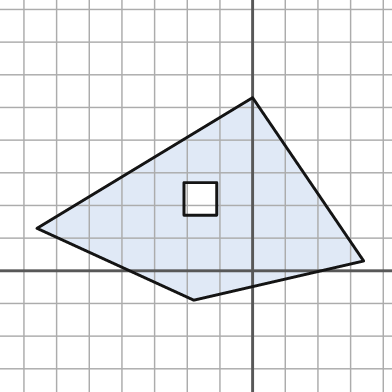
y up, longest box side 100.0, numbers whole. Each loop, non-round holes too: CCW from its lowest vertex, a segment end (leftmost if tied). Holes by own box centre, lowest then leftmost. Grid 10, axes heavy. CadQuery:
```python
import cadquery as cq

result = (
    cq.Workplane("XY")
    .moveTo(-18.0, -9.0)
    .lineTo(34.0, 3.0)
    .lineTo(0.0, 53.0)
    .lineTo(-66.0, 13.0)
    .close()
    .moveTo(-21.0, 17.0)
    .lineTo(-11.0, 17.0)
    .lineTo(-11.0, 27.0)
    .lineTo(-21.0, 27.0)
    .close()
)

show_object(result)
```